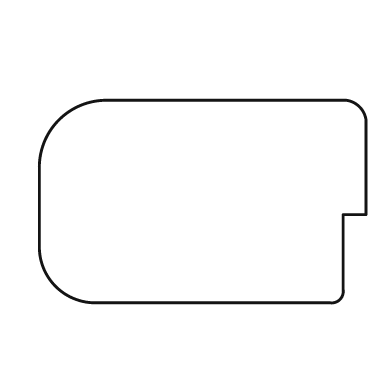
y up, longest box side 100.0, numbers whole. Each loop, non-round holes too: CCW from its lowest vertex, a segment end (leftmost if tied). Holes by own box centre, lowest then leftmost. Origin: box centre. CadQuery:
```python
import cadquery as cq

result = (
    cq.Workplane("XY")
    .moveTo(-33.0, -31.0)
    .lineTo(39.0, -31.0)
    .threePointArc((42.0, -30.0), (43.0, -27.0))
    .lineTo(43.0, -4.0)
    .lineTo(50.0, -4.0)
    .lineTo(50.0, 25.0)
    .threePointArc((48.0, 29.0), (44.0, 31.0))
    .lineTo(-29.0, 31.0)
    .threePointArc((-44.0, 25.0), (-50.0, 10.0))
    .lineTo(-50.0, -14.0)
    .threePointArc((-45.0, -26.0), (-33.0, -31.0))
    .close()
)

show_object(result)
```